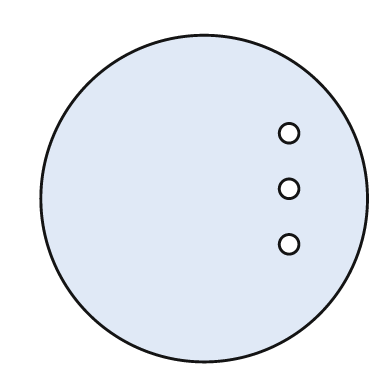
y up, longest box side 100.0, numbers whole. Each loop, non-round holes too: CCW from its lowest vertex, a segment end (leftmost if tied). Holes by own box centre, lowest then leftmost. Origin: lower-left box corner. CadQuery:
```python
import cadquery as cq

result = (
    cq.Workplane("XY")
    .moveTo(50.0, 50.0)
    .circle(50.0)
    .moveTo(76.0, 36.0)
    .circle(3.0)
    .moveTo(76.0, 53.0)
    .circle(3.0)
    .moveTo(76.0, 70.0)
    .circle(3.0)
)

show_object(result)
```